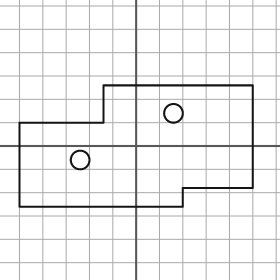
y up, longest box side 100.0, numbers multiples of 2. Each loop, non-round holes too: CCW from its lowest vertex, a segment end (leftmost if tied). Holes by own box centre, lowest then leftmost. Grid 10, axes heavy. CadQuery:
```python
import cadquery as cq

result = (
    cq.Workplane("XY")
    .moveTo(-50.0, -26.0)
    .lineTo(20.0, -26.0)
    .lineTo(20.0, -18.0)
    .lineTo(50.0, -18.0)
    .lineTo(50.0, 26.0)
    .lineTo(-14.0, 26.0)
    .lineTo(-14.0, 10.0)
    .lineTo(-50.0, 10.0)
    .close()
    .moveTo(-24.0, -6.0)
    .circle(4.0)
    .moveTo(16.0, 14.0)
    .circle(4.0)
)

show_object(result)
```